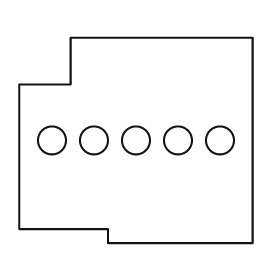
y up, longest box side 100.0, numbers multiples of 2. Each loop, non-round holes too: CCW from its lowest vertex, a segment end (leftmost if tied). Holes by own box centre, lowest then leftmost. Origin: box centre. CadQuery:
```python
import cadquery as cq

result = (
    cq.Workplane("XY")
    .moveTo(-12.0, -44.0)
    .lineTo(50.0, -44.0)
    .lineTo(50.0, 44.0)
    .lineTo(-28.0, 44.0)
    .lineTo(-28.0, 24.0)
    .lineTo(-50.0, 24.0)
    .lineTo(-50.0, -38.0)
    .lineTo(-12.0, -38.0)
    .close()
    .moveTo(-36.0, 0.0)
    .circle(6.0)
    .moveTo(-18.0, 0.0)
    .circle(6.0)
    .moveTo(0.0, 0.0)
    .circle(6.0)
    .moveTo(18.0, 0.0)
    .circle(6.0)
    .moveTo(36.0, 0.0)
    .circle(6.0)
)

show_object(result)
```